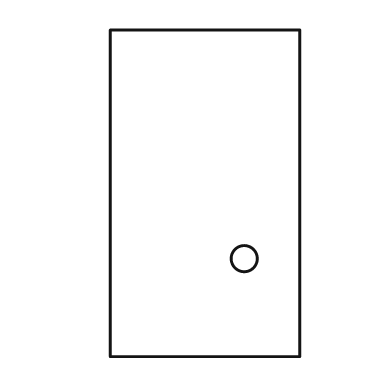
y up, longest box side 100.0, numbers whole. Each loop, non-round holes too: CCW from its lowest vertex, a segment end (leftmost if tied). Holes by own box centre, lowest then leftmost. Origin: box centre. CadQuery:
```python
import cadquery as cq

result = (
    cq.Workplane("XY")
    .moveTo(-29.0, -50.0)
    .lineTo(29.0, -50.0)
    .lineTo(29.0, 50.0)
    .lineTo(-29.0, 50.0)
    .close()
    .moveTo(12.0, -20.0)
    .circle(4.0)
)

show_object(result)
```